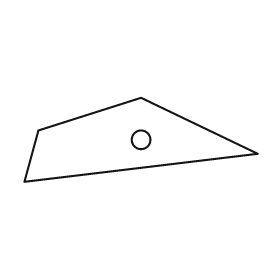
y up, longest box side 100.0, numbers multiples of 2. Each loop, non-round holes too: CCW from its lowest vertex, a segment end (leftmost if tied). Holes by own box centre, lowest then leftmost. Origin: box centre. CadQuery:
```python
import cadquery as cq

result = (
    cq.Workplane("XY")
    .moveTo(-50.0, -18.0)
    .lineTo(50.0, -6.0)
    .lineTo(0.0, 18.0)
    .lineTo(-44.0, 4.0)
    .close()
    .moveTo(0.0, 0.0)
    .circle(4.0)
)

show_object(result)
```